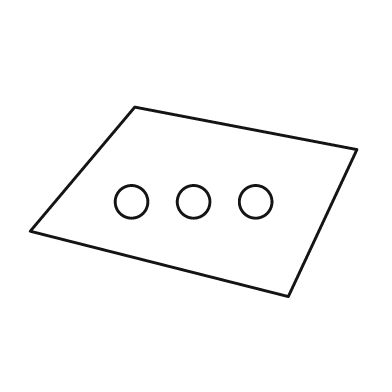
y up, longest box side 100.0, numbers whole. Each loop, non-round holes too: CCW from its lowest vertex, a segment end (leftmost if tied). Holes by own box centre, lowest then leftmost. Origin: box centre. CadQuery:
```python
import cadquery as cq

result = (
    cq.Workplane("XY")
    .moveTo(29.0, -29.0)
    .lineTo(50.0, 16.0)
    .lineTo(-18.0, 29.0)
    .lineTo(-50.0, -9.0)
    .close()
    .moveTo(-19.0, 0.0)
    .circle(5.0)
    .moveTo(0.0, 0.0)
    .circle(5.0)
    .moveTo(19.0, 0.0)
    .circle(5.0)
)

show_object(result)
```